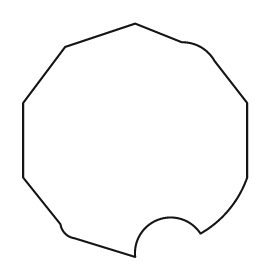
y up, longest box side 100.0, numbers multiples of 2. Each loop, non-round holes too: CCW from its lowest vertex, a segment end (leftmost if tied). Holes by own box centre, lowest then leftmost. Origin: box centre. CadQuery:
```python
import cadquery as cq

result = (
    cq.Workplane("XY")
    .moveTo(0.0, -50.0)
    .threePointArc((10.0, -34.0), (28.0, -40.0))
    .threePointArc((40.0, -30.0), (48.0, -16.0))
    .lineTo(48.0, 16.0)
    .lineTo(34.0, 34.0)
    .threePointArc((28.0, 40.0), (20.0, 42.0))
    .lineTo(0.0, 50.0)
    .lineTo(-30.0, 40.0)
    .lineTo(-48.0, 16.0)
    .lineTo(-48.0, -16.0)
    .lineTo(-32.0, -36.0)
    .threePointArc((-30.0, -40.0), (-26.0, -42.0))
    .close()
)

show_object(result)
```